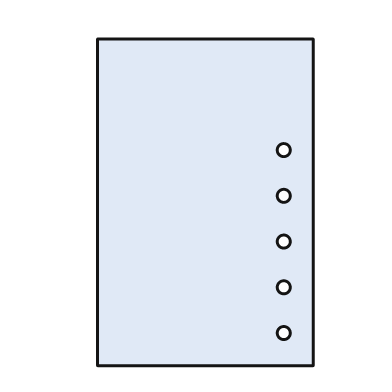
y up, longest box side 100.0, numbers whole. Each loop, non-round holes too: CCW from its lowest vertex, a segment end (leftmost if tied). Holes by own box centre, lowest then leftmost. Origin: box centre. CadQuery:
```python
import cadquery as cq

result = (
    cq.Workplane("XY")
    .moveTo(-33.0, -50.0)
    .lineTo(33.0, -50.0)
    .lineTo(33.0, 50.0)
    .lineTo(-33.0, 50.0)
    .close()
    .moveTo(24.0, -40.0)
    .circle(2.0)
    .moveTo(24.0, -26.0)
    .circle(2.0)
    .moveTo(24.0, -12.0)
    .circle(2.0)
    .moveTo(24.0, 2.0)
    .circle(2.0)
    .moveTo(24.0, 16.0)
    .circle(2.0)
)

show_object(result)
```